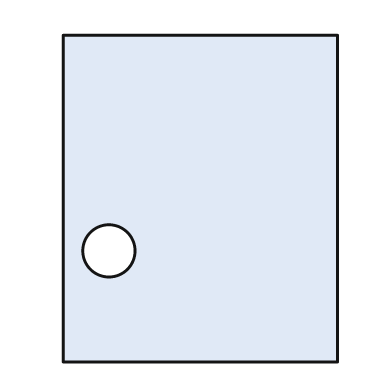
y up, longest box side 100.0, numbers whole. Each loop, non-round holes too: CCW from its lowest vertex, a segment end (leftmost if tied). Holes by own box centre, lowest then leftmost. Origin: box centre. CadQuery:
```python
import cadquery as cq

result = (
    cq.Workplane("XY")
    .moveTo(-42.0, -50.0)
    .lineTo(42.0, -50.0)
    .lineTo(42.0, 50.0)
    .lineTo(-42.0, 50.0)
    .close()
    .moveTo(-28.0, -16.0)
    .circle(8.0)
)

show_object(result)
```